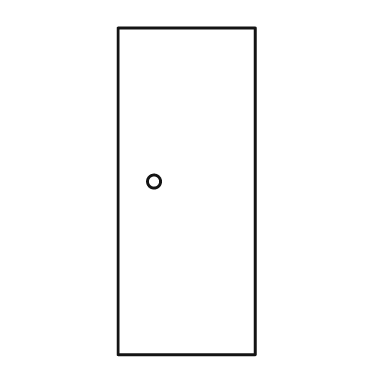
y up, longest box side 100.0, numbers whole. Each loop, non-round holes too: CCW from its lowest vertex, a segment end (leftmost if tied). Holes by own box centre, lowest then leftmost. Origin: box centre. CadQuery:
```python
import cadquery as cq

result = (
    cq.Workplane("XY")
    .moveTo(-21.0, -50.0)
    .lineTo(21.0, -50.0)
    .lineTo(21.0, 50.0)
    .lineTo(-21.0, 50.0)
    .close()
    .moveTo(-10.0, 3.0)
    .circle(2.0)
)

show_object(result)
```